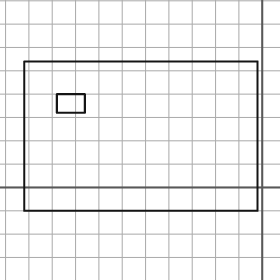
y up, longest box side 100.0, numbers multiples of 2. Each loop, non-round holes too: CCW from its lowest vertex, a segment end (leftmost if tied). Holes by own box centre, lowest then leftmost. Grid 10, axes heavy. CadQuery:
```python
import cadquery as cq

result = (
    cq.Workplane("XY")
    .moveTo(-102.0, -10.0)
    .lineTo(-2.0, -10.0)
    .lineTo(-2.0, 54.0)
    .lineTo(-102.0, 54.0)
    .close()
    .moveTo(-88.0, 32.0)
    .lineTo(-76.0, 32.0)
    .lineTo(-76.0, 40.0)
    .lineTo(-88.0, 40.0)
    .close()
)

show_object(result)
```